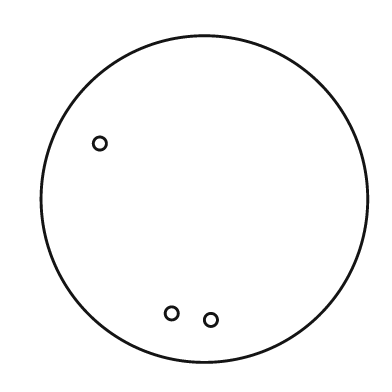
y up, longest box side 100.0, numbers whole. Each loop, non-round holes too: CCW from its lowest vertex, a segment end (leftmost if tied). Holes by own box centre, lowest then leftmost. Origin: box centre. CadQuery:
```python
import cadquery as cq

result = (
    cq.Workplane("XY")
    .moveTo(0.0, 0.0)
    .circle(50.0)
    .moveTo(2.0, -37.0)
    .circle(2.0)
    .moveTo(-10.0, -35.0)
    .circle(2.0)
    .moveTo(-32.0, 17.0)
    .circle(2.0)
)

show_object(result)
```